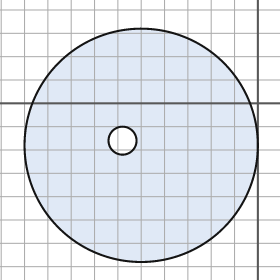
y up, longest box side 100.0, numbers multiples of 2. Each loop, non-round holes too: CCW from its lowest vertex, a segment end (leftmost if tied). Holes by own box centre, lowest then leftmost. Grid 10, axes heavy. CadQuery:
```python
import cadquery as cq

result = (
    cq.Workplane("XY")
    .moveTo(-50.0, -18.0)
    .circle(50.0)
    .moveTo(-58.0, -16.0)
    .circle(6.0)
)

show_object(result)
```